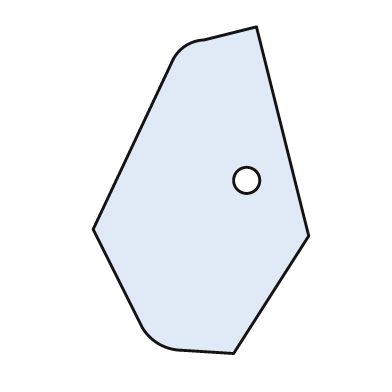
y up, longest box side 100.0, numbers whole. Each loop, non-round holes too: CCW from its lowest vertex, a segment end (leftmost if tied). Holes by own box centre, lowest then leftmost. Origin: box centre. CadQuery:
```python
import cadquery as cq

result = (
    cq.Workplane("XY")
    .moveTo(10.0, -50.0)
    .lineTo(33.0, -14.0)
    .lineTo(17.0, 50.0)
    .lineTo(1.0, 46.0)
    .threePointArc((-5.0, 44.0), (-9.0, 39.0))
    .lineTo(-33.0, -12.0)
    .lineTo(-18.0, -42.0)
    .threePointArc((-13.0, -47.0), (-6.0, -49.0))
    .close()
    .moveTo(14.0, 3.0)
    .circle(4.0)
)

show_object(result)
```